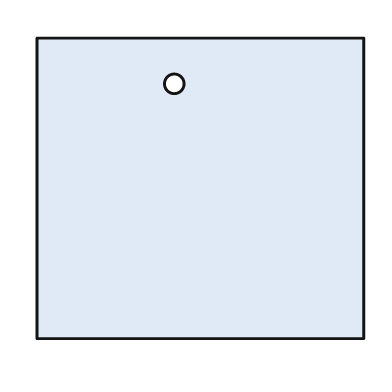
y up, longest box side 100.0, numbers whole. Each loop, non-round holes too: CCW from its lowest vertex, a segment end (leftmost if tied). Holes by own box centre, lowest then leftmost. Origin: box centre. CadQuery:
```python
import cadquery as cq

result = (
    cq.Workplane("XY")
    .moveTo(-50.0, -46.0)
    .lineTo(50.0, -46.0)
    .lineTo(50.0, 46.0)
    .lineTo(-50.0, 46.0)
    .close()
    .moveTo(-8.0, 32.0)
    .circle(3.0)
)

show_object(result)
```